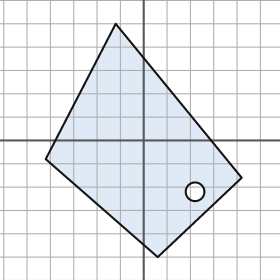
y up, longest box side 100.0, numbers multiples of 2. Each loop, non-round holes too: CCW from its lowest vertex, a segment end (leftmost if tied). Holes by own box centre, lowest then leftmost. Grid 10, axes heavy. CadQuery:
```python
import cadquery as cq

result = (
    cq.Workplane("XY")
    .moveTo(6.0, -50.0)
    .lineTo(42.0, -16.0)
    .lineTo(-12.0, 50.0)
    .lineTo(-42.0, -8.0)
    .close()
    .moveTo(22.0, -22.0)
    .circle(4.0)
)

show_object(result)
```